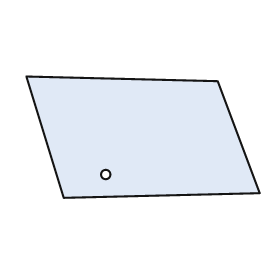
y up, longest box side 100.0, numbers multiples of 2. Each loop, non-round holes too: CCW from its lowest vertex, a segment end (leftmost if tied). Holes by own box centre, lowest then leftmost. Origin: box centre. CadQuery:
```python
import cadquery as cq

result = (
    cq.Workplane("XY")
    .moveTo(-34.0, -26.0)
    .lineTo(50.0, -24.0)
    .lineTo(32.0, 24.0)
    .lineTo(-50.0, 26.0)
    .close()
    .moveTo(-16.0, -16.0)
    .circle(2.0)
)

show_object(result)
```